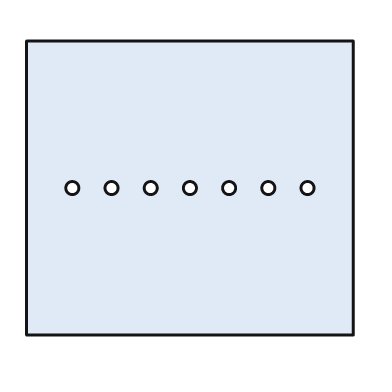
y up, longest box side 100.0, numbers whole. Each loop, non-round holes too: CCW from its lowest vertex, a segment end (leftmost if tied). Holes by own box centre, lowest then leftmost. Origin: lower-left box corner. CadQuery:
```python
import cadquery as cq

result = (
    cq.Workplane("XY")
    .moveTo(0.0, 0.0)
    .lineTo(100.0, 0.0)
    .lineTo(100.0, 90.0)
    .lineTo(0.0, 90.0)
    .close()
    .moveTo(14.0, 45.0)
    .circle(2.0)
    .moveTo(26.0, 45.0)
    .circle(2.0)
    .moveTo(38.0, 45.0)
    .circle(2.0)
    .moveTo(50.0, 45.0)
    .circle(2.0)
    .moveTo(62.0, 45.0)
    .circle(2.0)
    .moveTo(74.0, 45.0)
    .circle(2.0)
    .moveTo(86.0, 45.0)
    .circle(2.0)
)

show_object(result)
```